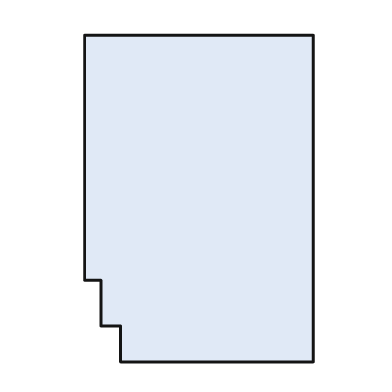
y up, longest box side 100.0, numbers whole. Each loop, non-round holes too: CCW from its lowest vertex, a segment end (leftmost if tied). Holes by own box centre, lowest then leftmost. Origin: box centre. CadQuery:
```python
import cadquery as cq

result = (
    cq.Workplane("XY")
    .moveTo(-24.0, -50.0)
    .lineTo(35.0, -50.0)
    .lineTo(35.0, 50.0)
    .lineTo(-35.0, 50.0)
    .lineTo(-35.0, -25.0)
    .lineTo(-30.0, -25.0)
    .lineTo(-30.0, -39.0)
    .lineTo(-24.0, -39.0)
    .close()
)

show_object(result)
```